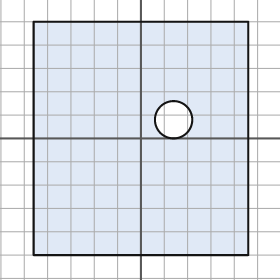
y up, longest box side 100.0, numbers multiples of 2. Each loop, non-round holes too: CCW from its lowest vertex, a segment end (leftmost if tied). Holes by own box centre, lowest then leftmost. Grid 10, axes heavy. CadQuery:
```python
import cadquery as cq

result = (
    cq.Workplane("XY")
    .moveTo(-46.0, -50.0)
    .lineTo(46.0, -50.0)
    .lineTo(46.0, 50.0)
    .lineTo(-46.0, 50.0)
    .close()
    .moveTo(14.0, 8.0)
    .circle(8.0)
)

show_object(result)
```